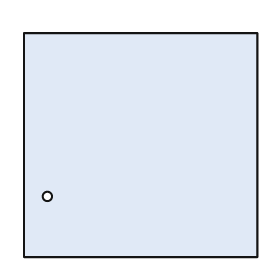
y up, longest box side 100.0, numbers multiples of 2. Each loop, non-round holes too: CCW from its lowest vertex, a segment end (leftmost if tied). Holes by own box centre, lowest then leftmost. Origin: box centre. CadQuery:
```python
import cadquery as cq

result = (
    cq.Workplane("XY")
    .moveTo(-50.0, -48.0)
    .lineTo(50.0, -48.0)
    .lineTo(50.0, 48.0)
    .lineTo(-50.0, 48.0)
    .close()
    .moveTo(-40.0, -22.0)
    .circle(2.0)
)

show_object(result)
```